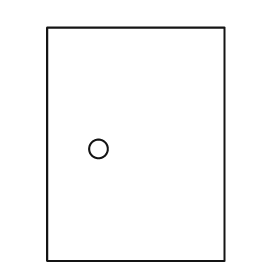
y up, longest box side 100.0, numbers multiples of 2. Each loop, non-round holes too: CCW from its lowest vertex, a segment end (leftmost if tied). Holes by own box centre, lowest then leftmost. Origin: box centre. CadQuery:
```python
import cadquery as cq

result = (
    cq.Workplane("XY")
    .moveTo(-38.0, -50.0)
    .lineTo(38.0, -50.0)
    .lineTo(38.0, 50.0)
    .lineTo(-38.0, 50.0)
    .close()
    .moveTo(-16.0, -2.0)
    .circle(4.0)
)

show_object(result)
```